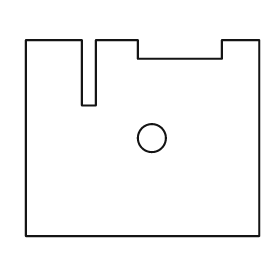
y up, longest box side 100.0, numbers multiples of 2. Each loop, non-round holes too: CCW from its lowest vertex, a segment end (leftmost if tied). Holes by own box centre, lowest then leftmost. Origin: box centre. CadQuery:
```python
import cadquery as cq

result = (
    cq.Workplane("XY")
    .moveTo(-50.0, -42.0)
    .lineTo(50.0, -42.0)
    .lineTo(50.0, 42.0)
    .lineTo(34.0, 42.0)
    .lineTo(34.0, 34.0)
    .lineTo(-2.0, 34.0)
    .lineTo(-2.0, 42.0)
    .lineTo(-20.0, 42.0)
    .lineTo(-20.0, 14.0)
    .lineTo(-26.0, 14.0)
    .lineTo(-26.0, 42.0)
    .lineTo(-50.0, 42.0)
    .close()
    .moveTo(4.0, 0.0)
    .circle(6.0)
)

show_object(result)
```